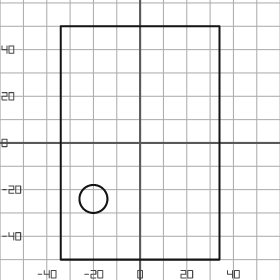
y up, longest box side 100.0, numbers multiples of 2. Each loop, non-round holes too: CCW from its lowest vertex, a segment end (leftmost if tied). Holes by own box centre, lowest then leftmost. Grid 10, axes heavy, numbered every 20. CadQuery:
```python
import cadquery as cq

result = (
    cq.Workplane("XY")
    .moveTo(-34.0, -50.0)
    .lineTo(34.0, -50.0)
    .lineTo(34.0, 50.0)
    .lineTo(-34.0, 50.0)
    .close()
    .moveTo(-20.0, -24.0)
    .circle(6.0)
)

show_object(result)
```